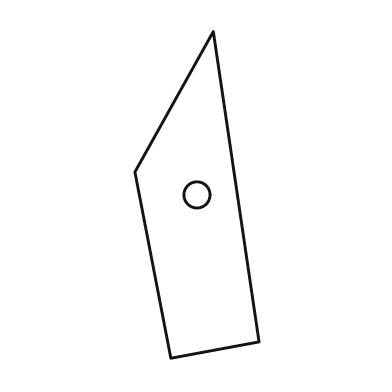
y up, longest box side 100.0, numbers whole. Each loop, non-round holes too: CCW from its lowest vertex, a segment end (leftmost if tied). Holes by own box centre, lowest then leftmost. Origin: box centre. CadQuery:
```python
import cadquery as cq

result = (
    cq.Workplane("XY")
    .moveTo(-8.0, -50.0)
    .lineTo(19.0, -45.0)
    .lineTo(5.0, 50.0)
    .lineTo(-19.0, 7.0)
    .close()
    .moveTo(0.0, 0.0)
    .circle(4.0)
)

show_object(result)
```